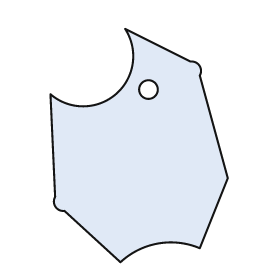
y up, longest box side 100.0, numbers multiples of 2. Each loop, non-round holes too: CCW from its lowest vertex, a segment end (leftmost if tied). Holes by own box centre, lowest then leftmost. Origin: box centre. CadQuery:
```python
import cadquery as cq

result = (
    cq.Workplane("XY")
    .moveTo(-8.0, -50.0)
    .threePointArc((8.0, -42.0), (26.0, -44.0))
    .lineTo(38.0, -14.0)
    .lineTo(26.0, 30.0)
    .threePointArc((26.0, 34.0), (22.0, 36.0))
    .lineTo(-6.0, 50.0)
    .threePointArc((-10.0, 22.0), (-38.0, 22.0))
    .lineTo(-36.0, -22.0)
    .threePointArc((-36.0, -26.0), (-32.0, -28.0))
    .close()
    .moveTo(4.0, 24.0)
    .circle(4.0)
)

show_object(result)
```